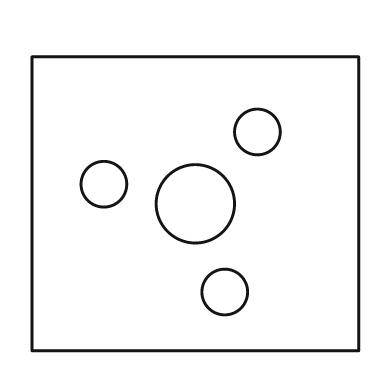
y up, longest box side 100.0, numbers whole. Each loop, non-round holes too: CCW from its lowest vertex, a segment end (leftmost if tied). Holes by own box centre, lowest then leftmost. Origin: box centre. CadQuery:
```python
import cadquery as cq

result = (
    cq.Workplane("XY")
    .moveTo(-50.0, -45.0)
    .lineTo(50.0, -45.0)
    .lineTo(50.0, 45.0)
    .lineTo(-50.0, 45.0)
    .close()
    .moveTo(9.0, -27.0)
    .circle(7.0)
    .moveTo(0.0, 0.0)
    .circle(12.0)
    .moveTo(-28.0, 6.0)
    .circle(7.0)
    .moveTo(19.0, 22.0)
    .circle(7.0)
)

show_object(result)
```